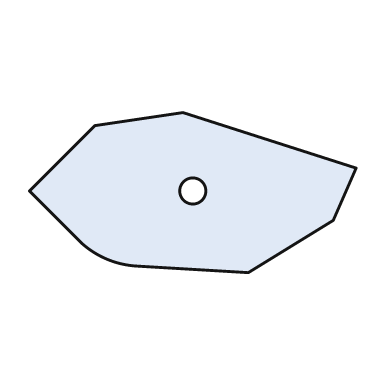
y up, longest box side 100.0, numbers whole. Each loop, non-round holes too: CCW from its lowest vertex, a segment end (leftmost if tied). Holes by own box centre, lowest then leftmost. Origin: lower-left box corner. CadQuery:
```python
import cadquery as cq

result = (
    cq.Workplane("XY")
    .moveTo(67.0, 0.0)
    .lineTo(93.0, 16.0)
    .lineTo(100.0, 32.0)
    .lineTo(47.0, 49.0)
    .lineTo(20.0, 45.0)
    .lineTo(0.0, 25.0)
    .lineTo(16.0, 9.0)
    .threePointArc((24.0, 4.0), (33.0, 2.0))
    .close()
    .moveTo(50.0, 25.0)
    .circle(4.0)
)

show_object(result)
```